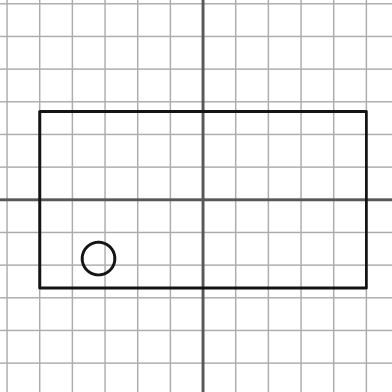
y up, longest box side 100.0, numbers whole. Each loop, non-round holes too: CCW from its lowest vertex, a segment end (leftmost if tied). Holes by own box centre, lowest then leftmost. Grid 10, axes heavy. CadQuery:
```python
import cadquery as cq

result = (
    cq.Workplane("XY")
    .moveTo(-50.0, -27.0)
    .lineTo(50.0, -27.0)
    .lineTo(50.0, 27.0)
    .lineTo(-50.0, 27.0)
    .close()
    .moveTo(-32.0, -18.0)
    .circle(5.0)
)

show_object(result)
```